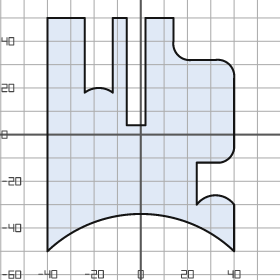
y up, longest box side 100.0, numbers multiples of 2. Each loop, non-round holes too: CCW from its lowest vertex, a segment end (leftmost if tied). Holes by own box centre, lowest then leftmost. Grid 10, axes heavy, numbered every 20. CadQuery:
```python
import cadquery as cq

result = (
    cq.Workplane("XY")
    .moveTo(-40.0, -50.0)
    .threePointArc((0.0, -34.0), (40.0, -50.0))
    .lineTo(40.0, -30.0)
    .threePointArc((32.0, -26.0), (24.0, -30.0))
    .lineTo(24.0, -12.0)
    .lineTo(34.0, -12.0)
    .threePointArc((38.0, -10.0), (40.0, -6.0))
    .lineTo(40.0, 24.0)
    .threePointArc((38.0, 30.0), (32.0, 32.0))
    .lineTo(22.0, 32.0)
    .threePointArc((16.0, 34.0), (14.0, 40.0))
    .lineTo(14.0, 50.0)
    .lineTo(2.0, 50.0)
    .lineTo(2.0, 4.0)
    .lineTo(-6.0, 4.0)
    .lineTo(-6.0, 50.0)
    .lineTo(-12.0, 50.0)
    .lineTo(-12.0, 18.0)
    .threePointArc((-18.0, 20.0), (-24.0, 18.0))
    .lineTo(-24.0, 50.0)
    .lineTo(-40.0, 50.0)
    .close()
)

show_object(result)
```